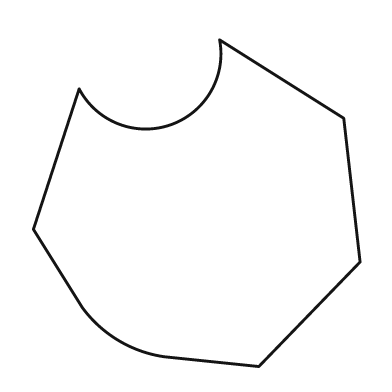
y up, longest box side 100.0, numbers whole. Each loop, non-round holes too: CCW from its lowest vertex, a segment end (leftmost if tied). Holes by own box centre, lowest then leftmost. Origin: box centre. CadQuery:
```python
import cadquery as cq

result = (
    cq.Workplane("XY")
    .moveTo(19.0, -50.0)
    .lineTo(50.0, -18.0)
    .lineTo(45.0, 26.0)
    .lineTo(7.0, 50.0)
    .threePointArc((-8.0, 24.0), (-36.0, 35.0))
    .lineTo(-50.0, -8.0)
    .lineTo(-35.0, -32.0)
    .threePointArc((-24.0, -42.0), (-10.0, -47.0))
    .close()
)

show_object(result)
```